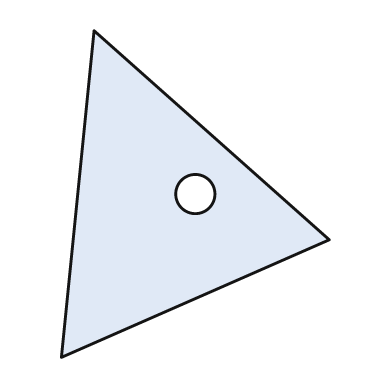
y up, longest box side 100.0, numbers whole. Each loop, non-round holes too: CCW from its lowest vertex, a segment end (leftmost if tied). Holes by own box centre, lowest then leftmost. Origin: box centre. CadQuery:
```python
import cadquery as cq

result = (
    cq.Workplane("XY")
    .moveTo(-41.0, -50.0)
    .lineTo(41.0, -14.0)
    .lineTo(-31.0, 50.0)
    .close()
    .moveTo(0.0, 0.0)
    .circle(6.0)
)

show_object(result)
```